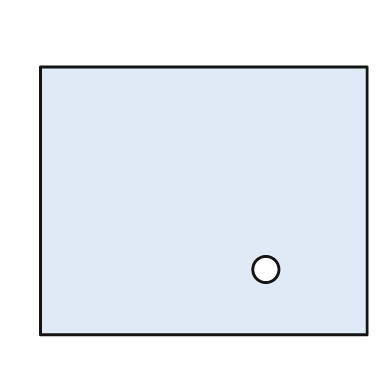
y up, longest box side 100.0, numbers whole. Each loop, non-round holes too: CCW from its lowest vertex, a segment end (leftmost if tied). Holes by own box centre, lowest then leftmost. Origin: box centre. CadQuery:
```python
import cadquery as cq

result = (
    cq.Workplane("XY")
    .moveTo(-50.0, -41.0)
    .lineTo(50.0, -41.0)
    .lineTo(50.0, 41.0)
    .lineTo(-50.0, 41.0)
    .close()
    .moveTo(19.0, -21.0)
    .circle(4.0)
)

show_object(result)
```